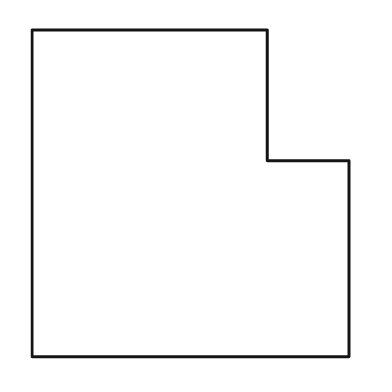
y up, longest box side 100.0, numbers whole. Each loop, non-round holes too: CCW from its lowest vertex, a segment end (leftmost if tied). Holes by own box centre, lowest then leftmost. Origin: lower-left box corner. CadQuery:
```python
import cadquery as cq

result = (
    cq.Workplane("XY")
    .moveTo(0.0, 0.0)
    .lineTo(97.0, 0.0)
    .lineTo(97.0, 60.0)
    .lineTo(72.0, 60.0)
    .lineTo(72.0, 100.0)
    .lineTo(0.0, 100.0)
    .close()
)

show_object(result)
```